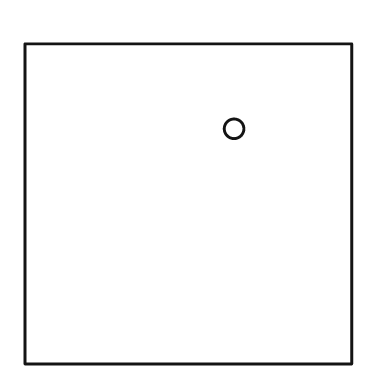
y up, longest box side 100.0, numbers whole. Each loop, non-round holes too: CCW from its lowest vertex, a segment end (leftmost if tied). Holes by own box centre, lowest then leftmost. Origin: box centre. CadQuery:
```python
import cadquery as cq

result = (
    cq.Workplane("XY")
    .moveTo(-50.0, -49.0)
    .lineTo(50.0, -49.0)
    .lineTo(50.0, 49.0)
    .lineTo(-50.0, 49.0)
    .close()
    .moveTo(14.0, 23.0)
    .circle(3.0)
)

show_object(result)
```